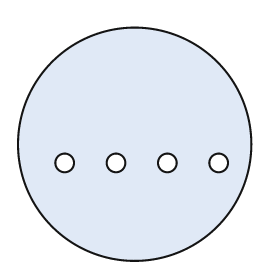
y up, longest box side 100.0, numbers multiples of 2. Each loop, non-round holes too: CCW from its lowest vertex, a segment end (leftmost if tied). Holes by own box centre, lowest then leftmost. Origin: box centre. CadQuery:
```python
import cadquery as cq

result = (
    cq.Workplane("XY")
    .moveTo(0.0, 0.0)
    .circle(50.0)
    .moveTo(-30.0, -8.0)
    .circle(4.0)
    .moveTo(-8.0, -8.0)
    .circle(4.0)
    .moveTo(14.0, -8.0)
    .circle(4.0)
    .moveTo(36.0, -8.0)
    .circle(4.0)
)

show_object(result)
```